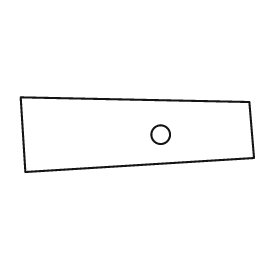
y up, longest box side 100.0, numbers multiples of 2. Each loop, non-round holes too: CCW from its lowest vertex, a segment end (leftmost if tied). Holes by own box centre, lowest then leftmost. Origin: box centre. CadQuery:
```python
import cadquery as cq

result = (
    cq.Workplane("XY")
    .moveTo(-48.0, -16.0)
    .lineTo(50.0, -10.0)
    .lineTo(48.0, 14.0)
    .lineTo(-50.0, 16.0)
    .close()
    .moveTo(10.0, 0.0)
    .circle(4.0)
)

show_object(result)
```